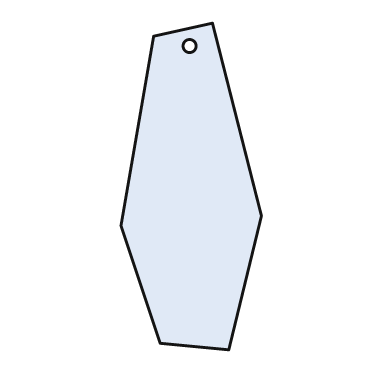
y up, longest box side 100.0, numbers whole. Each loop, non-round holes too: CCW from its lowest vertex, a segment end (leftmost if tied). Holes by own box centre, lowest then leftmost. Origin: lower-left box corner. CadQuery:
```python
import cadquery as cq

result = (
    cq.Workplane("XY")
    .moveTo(33.0, 0.0)
    .lineTo(43.0, 41.0)
    .lineTo(28.0, 100.0)
    .lineTo(10.0, 96.0)
    .lineTo(0.0, 38.0)
    .lineTo(12.0, 2.0)
    .close()
    .moveTo(21.0, 93.0)
    .circle(2.0)
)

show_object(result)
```